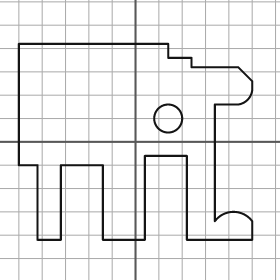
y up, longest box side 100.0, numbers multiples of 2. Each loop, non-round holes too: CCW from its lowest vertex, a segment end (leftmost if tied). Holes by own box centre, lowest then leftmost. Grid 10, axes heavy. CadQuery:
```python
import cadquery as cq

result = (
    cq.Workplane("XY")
    .moveTo(-42.0, -42.0)
    .lineTo(-32.0, -42.0)
    .lineTo(-32.0, -10.0)
    .lineTo(-14.0, -10.0)
    .lineTo(-14.0, -42.0)
    .lineTo(4.0, -42.0)
    .lineTo(4.0, -6.0)
    .lineTo(22.0, -6.0)
    .lineTo(22.0, -42.0)
    .lineTo(50.0, -42.0)
    .lineTo(50.0, -34.0)
    .threePointArc((42.0, -30.0), (34.0, -34.0))
    .lineTo(34.0, 16.0)
    .lineTo(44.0, 16.0)
    .threePointArc((48.0, 18.0), (50.0, 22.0))
    .lineTo(50.0, 26.0)
    .lineTo(44.0, 32.0)
    .lineTo(24.0, 32.0)
    .lineTo(24.0, 36.0)
    .lineTo(14.0, 36.0)
    .lineTo(14.0, 42.0)
    .lineTo(-50.0, 42.0)
    .lineTo(-50.0, -10.0)
    .lineTo(-42.0, -10.0)
    .close()
    .moveTo(14.0, 10.0)
    .circle(6.0)
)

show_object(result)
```